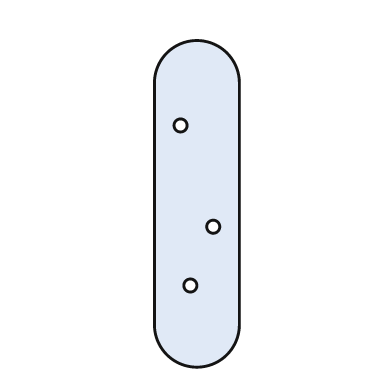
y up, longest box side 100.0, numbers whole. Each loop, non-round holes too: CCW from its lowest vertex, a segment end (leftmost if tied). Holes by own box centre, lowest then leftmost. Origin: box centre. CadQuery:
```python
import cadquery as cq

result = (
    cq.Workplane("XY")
    .moveTo(-13.0, -37.0)
    .threePointArc((0.0, -50.0), (13.0, -37.0))
    .lineTo(13.0, 37.0)
    .threePointArc((0.0, 50.0), (-13.0, 37.0))
    .close()
    .moveTo(-2.0, -25.0)
    .circle(2.0)
    .moveTo(5.0, -7.0)
    .circle(2.0)
    .moveTo(-5.0, 24.0)
    .circle(2.0)
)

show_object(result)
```